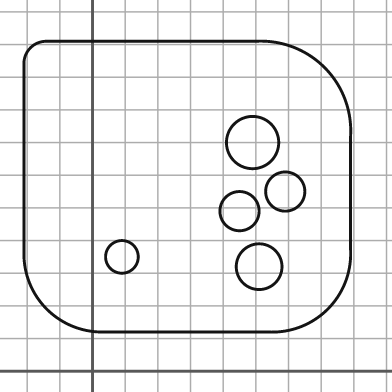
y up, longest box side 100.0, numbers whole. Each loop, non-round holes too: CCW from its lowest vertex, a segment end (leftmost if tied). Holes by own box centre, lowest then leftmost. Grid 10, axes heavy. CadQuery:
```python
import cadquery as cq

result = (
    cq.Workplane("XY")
    .moveTo(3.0, 12.0)
    .lineTo(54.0, 12.0)
    .threePointArc((72.0, 19.0), (79.0, 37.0))
    .lineTo(79.0, 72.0)
    .threePointArc((71.0, 93.0), (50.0, 101.0))
    .lineTo(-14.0, 101.0)
    .threePointArc((-19.0, 99.0), (-21.0, 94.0))
    .lineTo(-21.0, 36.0)
    .threePointArc((-14.0, 19.0), (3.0, 12.0))
    .close()
    .moveTo(51.0, 32.0)
    .circle(7.0)
    .moveTo(9.0, 35.0)
    .circle(5.0)
    .moveTo(45.0, 49.0)
    .circle(6.0)
    .moveTo(59.0, 55.0)
    .circle(6.0)
    .moveTo(49.0, 70.0)
    .circle(8.0)
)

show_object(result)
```